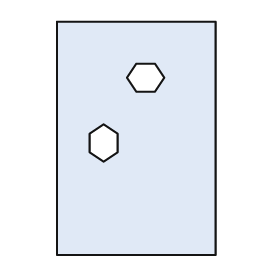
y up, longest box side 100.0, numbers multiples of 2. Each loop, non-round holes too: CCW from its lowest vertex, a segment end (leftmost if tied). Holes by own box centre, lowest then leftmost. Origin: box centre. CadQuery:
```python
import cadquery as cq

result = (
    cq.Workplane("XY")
    .moveTo(-34.0, -50.0)
    .lineTo(34.0, -50.0)
    .lineTo(34.0, 50.0)
    .lineTo(-34.0, 50.0)
    .close()
    .moveTo(-14.0, -10.0)
    .lineTo(-8.0, -6.0)
    .lineTo(-8.0, 2.0)
    .lineTo(-14.0, 6.0)
    .lineTo(-20.0, 2.0)
    .lineTo(-20.0, -6.0)
    .close()
    .moveTo(0.0, 20.0)
    .lineTo(8.0, 20.0)
    .lineTo(12.0, 26.0)
    .lineTo(8.0, 32.0)
    .lineTo(0.0, 32.0)
    .lineTo(-4.0, 26.0)
    .close()
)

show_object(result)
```